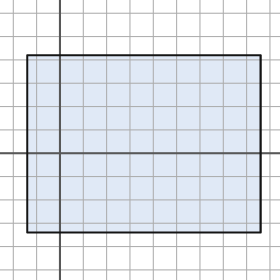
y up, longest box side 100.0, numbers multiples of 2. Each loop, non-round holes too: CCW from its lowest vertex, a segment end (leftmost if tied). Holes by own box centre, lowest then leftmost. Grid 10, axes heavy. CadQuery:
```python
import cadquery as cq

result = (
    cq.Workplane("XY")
    .moveTo(-14.0, -34.0)
    .lineTo(86.0, -34.0)
    .lineTo(86.0, 42.0)
    .lineTo(-14.0, 42.0)
    .close()
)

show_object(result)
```